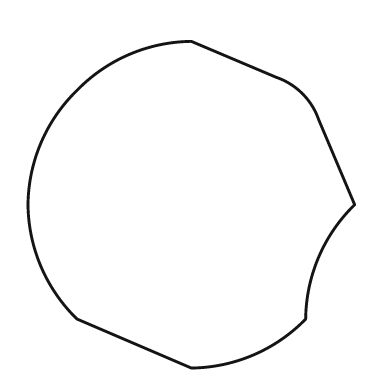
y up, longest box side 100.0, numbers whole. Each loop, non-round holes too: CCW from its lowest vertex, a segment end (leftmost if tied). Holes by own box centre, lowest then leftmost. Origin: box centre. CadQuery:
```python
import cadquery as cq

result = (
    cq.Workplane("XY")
    .moveTo(0.0, -50.0)
    .threePointArc((19.0, -46.0), (35.0, -35.0))
    .threePointArc((39.0, -16.0), (50.0, 0.0))
    .lineTo(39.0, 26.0)
    .threePointArc((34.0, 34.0), (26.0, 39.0))
    .lineTo(0.0, 50.0)
    .threePointArc((-19.0, 46.0), (-35.0, 35.0))
    .threePointArc((-46.0, 19.0), (-50.0, 0.0))
    .threePointArc((-46.0, -19.0), (-35.0, -35.0))
    .close()
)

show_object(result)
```